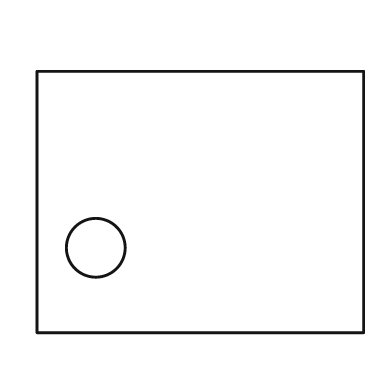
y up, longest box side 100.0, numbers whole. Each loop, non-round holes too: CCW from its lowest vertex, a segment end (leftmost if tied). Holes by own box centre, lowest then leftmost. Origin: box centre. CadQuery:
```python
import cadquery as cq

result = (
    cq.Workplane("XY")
    .moveTo(-50.0, -40.0)
    .lineTo(50.0, -40.0)
    .lineTo(50.0, 40.0)
    .lineTo(-50.0, 40.0)
    .close()
    .moveTo(-32.0, -14.0)
    .circle(9.0)
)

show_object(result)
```